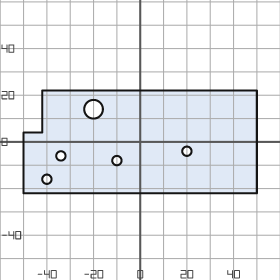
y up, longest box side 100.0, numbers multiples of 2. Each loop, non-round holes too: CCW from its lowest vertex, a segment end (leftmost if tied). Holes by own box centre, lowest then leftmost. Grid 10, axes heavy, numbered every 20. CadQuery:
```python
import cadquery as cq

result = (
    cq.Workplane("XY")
    .moveTo(-50.0, -22.0)
    .lineTo(50.0, -22.0)
    .lineTo(50.0, 22.0)
    .lineTo(-42.0, 22.0)
    .lineTo(-42.0, 4.0)
    .lineTo(-50.0, 4.0)
    .close()
    .moveTo(-40.0, -16.0)
    .circle(2.0)
    .moveTo(-10.0, -8.0)
    .circle(2.0)
    .moveTo(-34.0, -6.0)
    .circle(2.0)
    .moveTo(20.0, -4.0)
    .circle(2.0)
    .moveTo(-20.0, 14.0)
    .circle(4.0)
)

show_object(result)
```